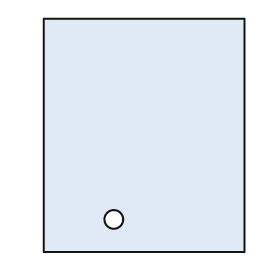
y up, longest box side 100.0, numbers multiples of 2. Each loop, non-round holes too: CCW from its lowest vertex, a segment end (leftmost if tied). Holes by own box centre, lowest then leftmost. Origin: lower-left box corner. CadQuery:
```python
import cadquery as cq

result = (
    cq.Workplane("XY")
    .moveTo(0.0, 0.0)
    .lineTo(86.0, 0.0)
    .lineTo(86.0, 100.0)
    .lineTo(0.0, 100.0)
    .close()
    .moveTo(30.0, 14.0)
    .circle(4.0)
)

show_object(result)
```